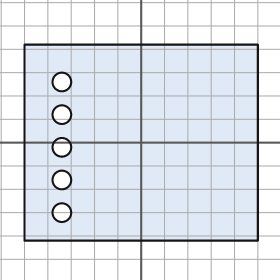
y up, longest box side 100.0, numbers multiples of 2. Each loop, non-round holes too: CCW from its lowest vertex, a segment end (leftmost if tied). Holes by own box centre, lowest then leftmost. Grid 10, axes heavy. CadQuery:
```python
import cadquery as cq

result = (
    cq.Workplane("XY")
    .moveTo(-50.0, -42.0)
    .lineTo(50.0, -42.0)
    .lineTo(50.0, 42.0)
    .lineTo(-50.0, 42.0)
    .close()
    .moveTo(-34.0, -30.0)
    .circle(4.0)
    .moveTo(-34.0, -16.0)
    .circle(4.0)
    .moveTo(-34.0, -2.0)
    .circle(4.0)
    .moveTo(-34.0, 12.0)
    .circle(4.0)
    .moveTo(-34.0, 26.0)
    .circle(4.0)
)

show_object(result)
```